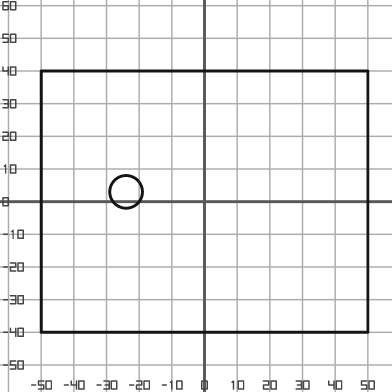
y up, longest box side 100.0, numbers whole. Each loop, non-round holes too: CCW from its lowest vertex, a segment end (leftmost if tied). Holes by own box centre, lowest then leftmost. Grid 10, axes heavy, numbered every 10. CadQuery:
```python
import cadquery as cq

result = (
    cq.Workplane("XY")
    .moveTo(-50.0, -40.0)
    .lineTo(50.0, -40.0)
    .lineTo(50.0, 40.0)
    .lineTo(-50.0, 40.0)
    .close()
    .moveTo(-24.0, 3.0)
    .circle(5.0)
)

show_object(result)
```